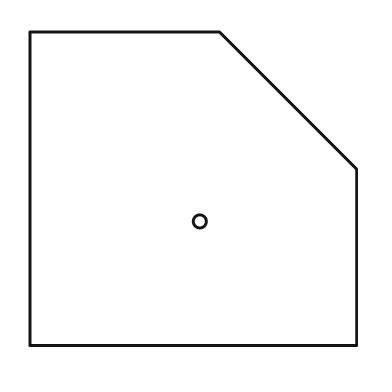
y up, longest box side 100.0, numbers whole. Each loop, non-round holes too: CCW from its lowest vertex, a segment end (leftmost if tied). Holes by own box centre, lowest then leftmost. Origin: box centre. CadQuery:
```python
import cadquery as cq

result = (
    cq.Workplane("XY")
    .moveTo(-50.0, -48.0)
    .lineTo(50.0, -48.0)
    .lineTo(50.0, 6.0)
    .lineTo(8.0, 48.0)
    .lineTo(-50.0, 48.0)
    .close()
    .moveTo(2.0, -10.0)
    .circle(2.0)
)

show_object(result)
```